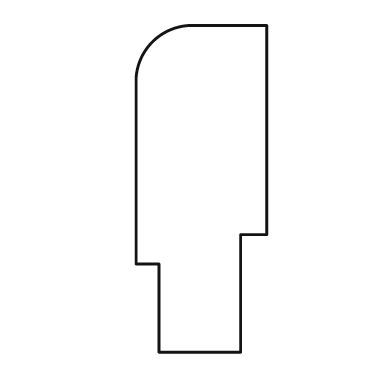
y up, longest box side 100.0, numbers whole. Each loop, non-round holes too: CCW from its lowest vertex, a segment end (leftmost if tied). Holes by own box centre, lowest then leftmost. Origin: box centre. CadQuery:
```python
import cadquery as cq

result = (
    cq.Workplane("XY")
    .moveTo(-13.0, -50.0)
    .lineTo(12.0, -50.0)
    .lineTo(12.0, -14.0)
    .lineTo(20.0, -14.0)
    .lineTo(20.0, 50.0)
    .lineTo(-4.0, 50.0)
    .threePointArc((-15.0, 45.0), (-20.0, 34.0))
    .lineTo(-20.0, -23.0)
    .lineTo(-13.0, -23.0)
    .close()
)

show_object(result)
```